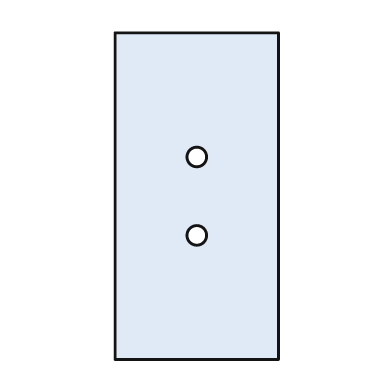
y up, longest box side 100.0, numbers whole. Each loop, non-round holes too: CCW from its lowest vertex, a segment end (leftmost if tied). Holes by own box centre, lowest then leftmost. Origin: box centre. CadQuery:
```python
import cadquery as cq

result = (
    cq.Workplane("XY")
    .moveTo(-25.0, -50.0)
    .lineTo(25.0, -50.0)
    .lineTo(25.0, 50.0)
    .lineTo(-25.0, 50.0)
    .close()
    .moveTo(0.0, -12.0)
    .circle(3.0)
    .moveTo(0.0, 12.0)
    .circle(3.0)
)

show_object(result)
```